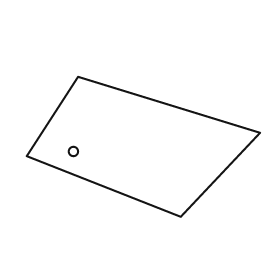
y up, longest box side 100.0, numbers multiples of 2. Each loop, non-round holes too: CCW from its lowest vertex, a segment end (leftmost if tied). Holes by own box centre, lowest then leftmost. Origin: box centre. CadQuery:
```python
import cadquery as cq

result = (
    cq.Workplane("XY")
    .moveTo(16.0, -30.0)
    .lineTo(50.0, 6.0)
    .lineTo(-28.0, 30.0)
    .lineTo(-50.0, -4.0)
    .close()
    .moveTo(-30.0, -2.0)
    .circle(2.0)
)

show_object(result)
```